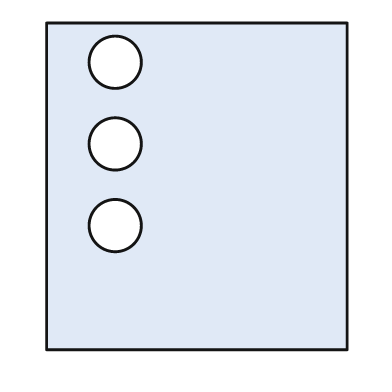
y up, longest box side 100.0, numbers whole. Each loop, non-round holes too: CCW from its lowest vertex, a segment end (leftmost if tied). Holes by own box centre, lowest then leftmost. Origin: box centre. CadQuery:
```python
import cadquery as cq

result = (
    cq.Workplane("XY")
    .moveTo(-46.0, -50.0)
    .lineTo(46.0, -50.0)
    .lineTo(46.0, 50.0)
    .lineTo(-46.0, 50.0)
    .close()
    .moveTo(-25.0, -12.0)
    .circle(8.0)
    .moveTo(-25.0, 13.0)
    .circle(8.0)
    .moveTo(-25.0, 38.0)
    .circle(8.0)
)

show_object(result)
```